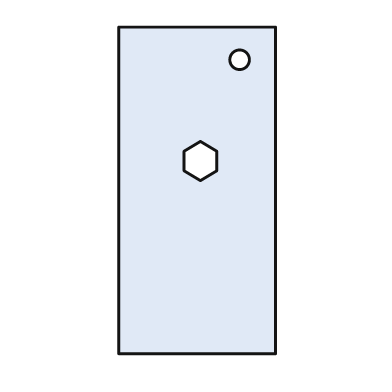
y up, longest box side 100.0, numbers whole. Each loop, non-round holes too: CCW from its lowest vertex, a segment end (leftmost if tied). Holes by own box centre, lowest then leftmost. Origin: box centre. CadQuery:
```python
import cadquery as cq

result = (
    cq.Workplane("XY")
    .moveTo(-24.0, -50.0)
    .lineTo(24.0, -50.0)
    .lineTo(24.0, 50.0)
    .lineTo(-24.0, 50.0)
    .close()
    .moveTo(1.0, 3.0)
    .lineTo(6.0, 6.0)
    .lineTo(6.0, 12.0)
    .lineTo(1.0, 15.0)
    .lineTo(-4.0, 12.0)
    .lineTo(-4.0, 6.0)
    .close()
    .moveTo(13.0, 40.0)
    .circle(3.0)
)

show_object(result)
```